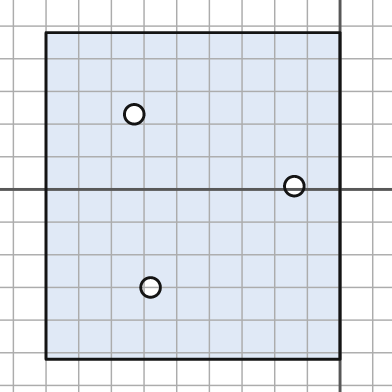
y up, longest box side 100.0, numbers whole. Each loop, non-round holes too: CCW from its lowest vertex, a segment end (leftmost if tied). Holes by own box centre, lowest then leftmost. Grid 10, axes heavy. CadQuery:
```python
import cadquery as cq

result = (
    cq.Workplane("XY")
    .moveTo(-90.0, -52.0)
    .lineTo(0.0, -52.0)
    .lineTo(0.0, 48.0)
    .lineTo(-90.0, 48.0)
    .close()
    .moveTo(-58.0, -30.0)
    .circle(3.0)
    .moveTo(-14.0, 1.0)
    .circle(3.0)
    .moveTo(-63.0, 23.0)
    .circle(3.0)
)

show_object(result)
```